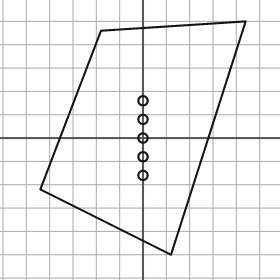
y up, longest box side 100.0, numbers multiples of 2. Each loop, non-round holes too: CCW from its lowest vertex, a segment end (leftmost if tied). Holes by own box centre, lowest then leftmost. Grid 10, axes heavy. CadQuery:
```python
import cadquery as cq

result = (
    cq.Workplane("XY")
    .moveTo(12.0, -50.0)
    .lineTo(44.0, 50.0)
    .lineTo(-18.0, 46.0)
    .lineTo(-44.0, -22.0)
    .close()
    .moveTo(0.0, -16.0)
    .circle(2.0)
    .moveTo(0.0, -8.0)
    .circle(2.0)
    .moveTo(0.0, 0.0)
    .circle(2.0)
    .moveTo(0.0, 8.0)
    .circle(2.0)
    .moveTo(0.0, 16.0)
    .circle(2.0)
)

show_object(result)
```